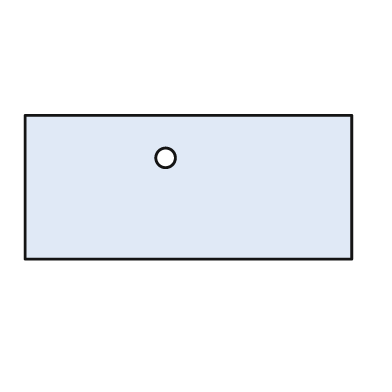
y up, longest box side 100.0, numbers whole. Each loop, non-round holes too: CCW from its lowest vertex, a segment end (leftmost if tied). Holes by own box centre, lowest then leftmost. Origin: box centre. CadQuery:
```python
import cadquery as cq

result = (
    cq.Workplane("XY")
    .moveTo(-50.0, -22.0)
    .lineTo(50.0, -22.0)
    .lineTo(50.0, 22.0)
    .lineTo(-50.0, 22.0)
    .close()
    .moveTo(-7.0, 9.0)
    .circle(3.0)
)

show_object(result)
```